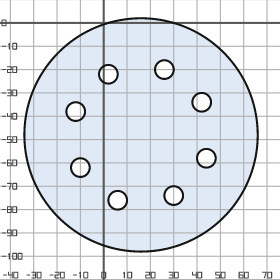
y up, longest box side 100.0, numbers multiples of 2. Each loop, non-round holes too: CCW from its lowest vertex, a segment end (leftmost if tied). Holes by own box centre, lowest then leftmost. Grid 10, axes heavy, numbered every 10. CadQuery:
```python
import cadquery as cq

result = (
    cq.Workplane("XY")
    .moveTo(16.0, -48.0)
    .circle(50.0)
    .moveTo(6.0, -76.0)
    .circle(4.0)
    .moveTo(30.0, -74.0)
    .circle(4.0)
    .moveTo(-10.0, -62.0)
    .circle(4.0)
    .moveTo(44.0, -58.0)
    .circle(4.0)
    .moveTo(-12.0, -38.0)
    .circle(4.0)
    .moveTo(42.0, -34.0)
    .circle(4.0)
    .moveTo(2.0, -22.0)
    .circle(4.0)
    .moveTo(26.0, -20.0)
    .circle(4.0)
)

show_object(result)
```